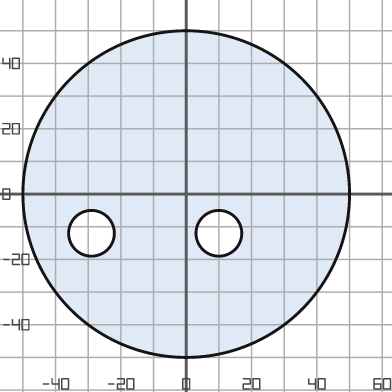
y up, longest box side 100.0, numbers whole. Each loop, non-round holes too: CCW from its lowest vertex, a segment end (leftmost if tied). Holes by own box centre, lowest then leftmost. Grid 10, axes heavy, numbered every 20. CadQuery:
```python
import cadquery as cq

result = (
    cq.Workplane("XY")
    .moveTo(0.0, 0.0)
    .circle(50.0)
    .moveTo(-29.0, -12.0)
    .circle(7.0)
    .moveTo(10.0, -12.0)
    .circle(7.0)
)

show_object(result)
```